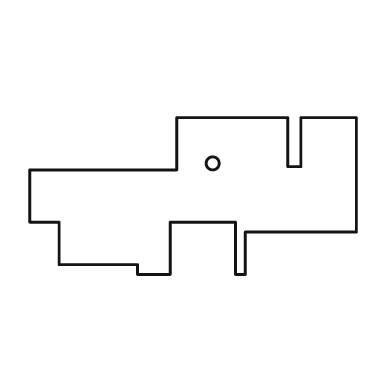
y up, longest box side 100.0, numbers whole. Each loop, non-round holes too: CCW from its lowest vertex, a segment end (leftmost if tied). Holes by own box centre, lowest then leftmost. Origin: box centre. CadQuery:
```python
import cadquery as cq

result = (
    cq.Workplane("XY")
    .moveTo(-17.0, -24.0)
    .lineTo(-7.0, -24.0)
    .lineTo(-7.0, -8.0)
    .lineTo(13.0, -8.0)
    .lineTo(13.0, -24.0)
    .lineTo(16.0, -24.0)
    .lineTo(16.0, -11.0)
    .lineTo(50.0, -11.0)
    .lineTo(50.0, 24.0)
    .lineTo(33.0, 24.0)
    .lineTo(33.0, 9.0)
    .lineTo(29.0, 9.0)
    .lineTo(29.0, 24.0)
    .lineTo(-5.0, 24.0)
    .lineTo(-5.0, 8.0)
    .lineTo(-50.0, 8.0)
    .lineTo(-50.0, -8.0)
    .lineTo(-41.0, -8.0)
    .lineTo(-41.0, -21.0)
    .lineTo(-17.0, -21.0)
    .close()
    .moveTo(6.0, 10.0)
    .circle(2.0)
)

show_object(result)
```